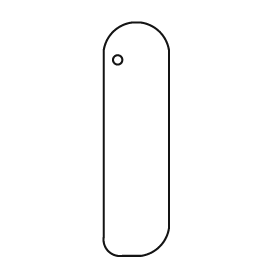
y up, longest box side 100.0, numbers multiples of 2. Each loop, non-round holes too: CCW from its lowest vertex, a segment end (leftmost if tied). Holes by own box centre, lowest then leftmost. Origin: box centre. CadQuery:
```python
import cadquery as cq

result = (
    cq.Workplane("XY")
    .moveTo(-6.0, -50.0)
    .lineTo(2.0, -50.0)
    .threePointArc((10.0, -46.0), (14.0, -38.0))
    .lineTo(14.0, 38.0)
    .threePointArc((10.0, 46.0), (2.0, 50.0))
    .lineTo(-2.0, 50.0)
    .threePointArc((-10.0, 46.0), (-14.0, 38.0))
    .lineTo(-14.0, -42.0)
    .threePointArc((-12.0, -48.0), (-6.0, -50.0))
    .close()
    .moveTo(-8.0, 34.0)
    .circle(2.0)
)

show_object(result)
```